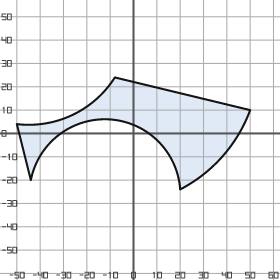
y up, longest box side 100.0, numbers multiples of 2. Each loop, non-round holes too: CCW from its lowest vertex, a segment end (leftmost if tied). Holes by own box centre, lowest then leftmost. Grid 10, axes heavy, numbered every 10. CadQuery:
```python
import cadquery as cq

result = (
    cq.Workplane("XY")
    .moveTo(20.0, -24.0)
    .threePointArc((38.0, -10.0), (50.0, 10.0))
    .lineTo(-8.0, 24.0)
    .threePointArc((-26.0, 8.0), (-50.0, 4.0))
    .lineTo(-44.0, -20.0)
    .threePointArc((-10.0, 6.0), (20.0, -24.0))
    .close()
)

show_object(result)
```